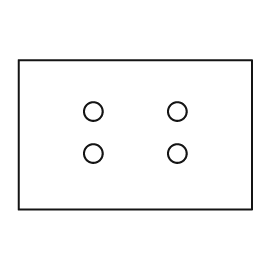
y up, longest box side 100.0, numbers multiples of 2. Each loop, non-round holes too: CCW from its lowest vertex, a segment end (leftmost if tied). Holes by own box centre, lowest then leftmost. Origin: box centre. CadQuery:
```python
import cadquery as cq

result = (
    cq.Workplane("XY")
    .moveTo(-50.0, -32.0)
    .lineTo(50.0, -32.0)
    .lineTo(50.0, 32.0)
    .lineTo(-50.0, 32.0)
    .close()
    .moveTo(-18.0, -8.0)
    .circle(4.0)
    .moveTo(18.0, -8.0)
    .circle(4.0)
    .moveTo(-18.0, 10.0)
    .circle(4.0)
    .moveTo(18.0, 10.0)
    .circle(4.0)
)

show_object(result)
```